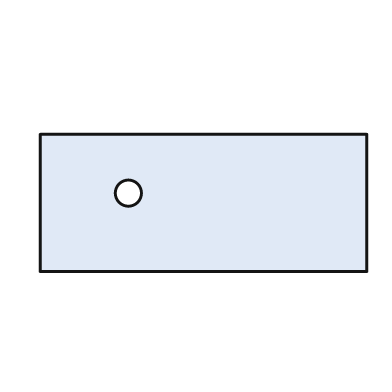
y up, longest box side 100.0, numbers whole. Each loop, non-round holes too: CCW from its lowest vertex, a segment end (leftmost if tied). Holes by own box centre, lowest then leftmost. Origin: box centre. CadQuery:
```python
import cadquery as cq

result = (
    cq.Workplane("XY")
    .moveTo(-50.0, -21.0)
    .lineTo(50.0, -21.0)
    .lineTo(50.0, 21.0)
    .lineTo(-50.0, 21.0)
    .close()
    .moveTo(-23.0, 3.0)
    .circle(4.0)
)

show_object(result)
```